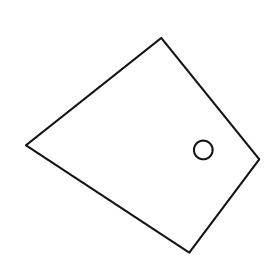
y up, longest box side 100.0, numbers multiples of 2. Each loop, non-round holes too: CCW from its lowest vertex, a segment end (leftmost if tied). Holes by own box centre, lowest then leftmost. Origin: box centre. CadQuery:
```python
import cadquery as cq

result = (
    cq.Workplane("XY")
    .moveTo(20.0, -46.0)
    .lineTo(50.0, -6.0)
    .lineTo(8.0, 46.0)
    .lineTo(-50.0, 0.0)
    .close()
    .moveTo(26.0, -2.0)
    .circle(4.0)
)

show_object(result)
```